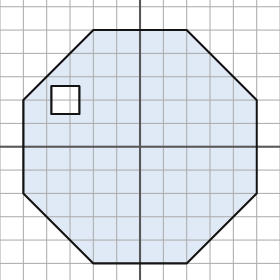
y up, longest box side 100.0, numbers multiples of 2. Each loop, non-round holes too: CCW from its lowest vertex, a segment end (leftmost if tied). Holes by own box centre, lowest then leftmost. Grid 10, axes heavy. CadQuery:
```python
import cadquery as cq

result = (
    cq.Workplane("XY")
    .moveTo(-20.0, -50.0)
    .lineTo(20.0, -50.0)
    .lineTo(50.0, -20.0)
    .lineTo(50.0, 20.0)
    .lineTo(20.0, 50.0)
    .lineTo(-20.0, 50.0)
    .lineTo(-50.0, 20.0)
    .lineTo(-50.0, -20.0)
    .close()
    .moveTo(-38.0, 14.0)
    .lineTo(-26.0, 14.0)
    .lineTo(-26.0, 26.0)
    .lineTo(-38.0, 26.0)
    .close()
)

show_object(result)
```